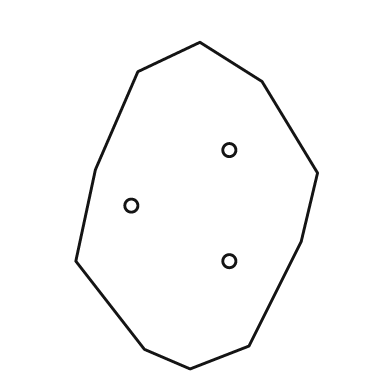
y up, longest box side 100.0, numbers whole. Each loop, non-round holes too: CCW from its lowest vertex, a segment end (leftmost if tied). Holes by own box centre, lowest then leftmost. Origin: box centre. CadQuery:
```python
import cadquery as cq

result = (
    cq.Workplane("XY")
    .moveTo(-2.0, -50.0)
    .lineTo(16.0, -43.0)
    .lineTo(32.0, -11.0)
    .lineTo(37.0, 10.0)
    .lineTo(20.0, 38.0)
    .lineTo(1.0, 50.0)
    .lineTo(-18.0, 41.0)
    .lineTo(-31.0, 11.0)
    .lineTo(-37.0, -17.0)
    .lineTo(-16.0, -44.0)
    .close()
    .moveTo(10.0, -17.0)
    .circle(2.0)
    .moveTo(-20.0, 0.0)
    .circle(2.0)
    .moveTo(10.0, 17.0)
    .circle(2.0)
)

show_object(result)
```